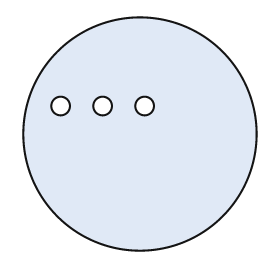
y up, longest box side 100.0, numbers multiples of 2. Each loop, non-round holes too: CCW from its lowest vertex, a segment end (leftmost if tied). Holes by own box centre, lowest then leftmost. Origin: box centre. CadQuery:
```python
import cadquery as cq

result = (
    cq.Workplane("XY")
    .moveTo(0.0, 0.0)
    .circle(50.0)
    .moveTo(-34.0, 12.0)
    .circle(4.0)
    .moveTo(-16.0, 12.0)
    .circle(4.0)
    .moveTo(2.0, 12.0)
    .circle(4.0)
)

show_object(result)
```